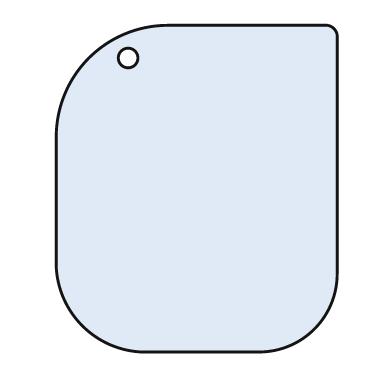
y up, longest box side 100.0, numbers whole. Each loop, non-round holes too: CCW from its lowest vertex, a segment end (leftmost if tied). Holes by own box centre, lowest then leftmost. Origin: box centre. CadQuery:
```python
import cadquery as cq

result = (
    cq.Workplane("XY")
    .moveTo(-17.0, -50.0)
    .lineTo(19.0, -50.0)
    .threePointArc((36.0, -43.0), (43.0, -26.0))
    .lineTo(43.0, 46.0)
    .threePointArc((42.0, 49.0), (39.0, 50.0))
    .lineTo(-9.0, 50.0)
    .threePointArc((-33.0, 40.0), (-43.0, 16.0))
    .lineTo(-43.0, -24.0)
    .threePointArc((-35.0, -42.0), (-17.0, -50.0))
    .close()
    .moveTo(-21.0, 40.0)
    .circle(3.0)
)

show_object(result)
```